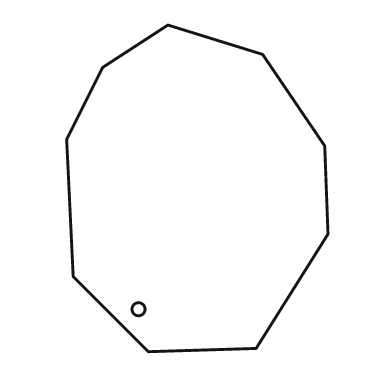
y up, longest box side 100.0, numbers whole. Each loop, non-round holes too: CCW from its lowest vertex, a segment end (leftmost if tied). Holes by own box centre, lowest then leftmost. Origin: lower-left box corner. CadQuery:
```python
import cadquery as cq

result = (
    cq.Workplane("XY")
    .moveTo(25.0, 0.0)
    .lineTo(58.0, 1.0)
    .lineTo(80.0, 36.0)
    .lineTo(79.0, 63.0)
    .lineTo(60.0, 91.0)
    .lineTo(31.0, 100.0)
    .lineTo(11.0, 87.0)
    .lineTo(0.0, 65.0)
    .lineTo(2.0, 23.0)
    .close()
    .moveTo(22.0, 13.0)
    .circle(2.0)
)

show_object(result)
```